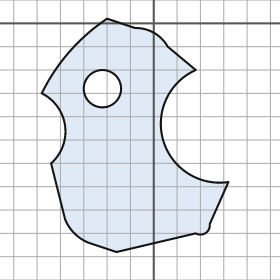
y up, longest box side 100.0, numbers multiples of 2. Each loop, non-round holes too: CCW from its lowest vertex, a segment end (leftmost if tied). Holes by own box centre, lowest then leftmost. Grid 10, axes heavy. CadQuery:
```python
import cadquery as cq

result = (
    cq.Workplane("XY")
    .moveTo(-16.0, -98.0)
    .lineTo(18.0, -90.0)
    .threePointArc((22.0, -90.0), (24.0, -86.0))
    .lineTo(32.0, -68.0)
    .threePointArc((4.0, -50.0), (18.0, -20.0))
    .lineTo(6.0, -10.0)
    .threePointArc((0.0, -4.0), (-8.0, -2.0))
    .lineTo(-20.0, 2.0)
    .threePointArc((-36.0, -12.0), (-48.0, -30.0))
    .threePointArc((-38.0, -44.0), (-44.0, -60.0))
    .lineTo(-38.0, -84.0)
    .threePointArc((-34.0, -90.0), (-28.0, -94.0))
    .close()
    .moveTo(-22.0, -28.0)
    .circle(8.0)
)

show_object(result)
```